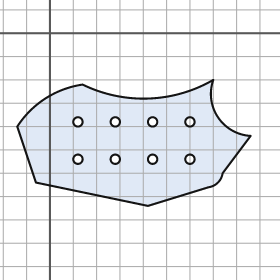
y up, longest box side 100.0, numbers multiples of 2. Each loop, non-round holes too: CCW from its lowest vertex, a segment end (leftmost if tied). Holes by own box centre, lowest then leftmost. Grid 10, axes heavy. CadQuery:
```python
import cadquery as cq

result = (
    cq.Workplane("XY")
    .moveTo(42.0, -74.0)
    .lineTo(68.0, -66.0)
    .threePointArc((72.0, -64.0), (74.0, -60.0))
    .lineTo(86.0, -44.0)
    .threePointArc((72.0, -36.0), (70.0, -20.0))
    .threePointArc((42.0, -28.0), (14.0, -22.0))
    .threePointArc((-2.0, -28.0), (-14.0, -40.0))
    .lineTo(-6.0, -64.0)
    .close()
    .moveTo(12.0, -54.0)
    .circle(2.0)
    .moveTo(28.0, -54.0)
    .circle(2.0)
    .moveTo(44.0, -54.0)
    .circle(2.0)
    .moveTo(60.0, -54.0)
    .circle(2.0)
    .moveTo(12.0, -38.0)
    .circle(2.0)
    .moveTo(28.0, -38.0)
    .circle(2.0)
    .moveTo(44.0, -38.0)
    .circle(2.0)
    .moveTo(60.0, -38.0)
    .circle(2.0)
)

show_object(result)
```